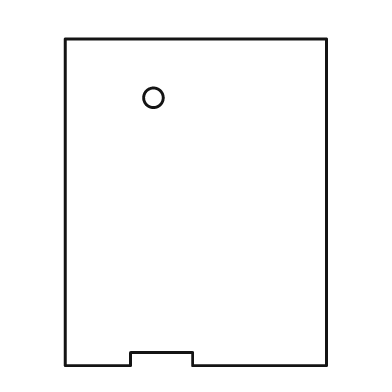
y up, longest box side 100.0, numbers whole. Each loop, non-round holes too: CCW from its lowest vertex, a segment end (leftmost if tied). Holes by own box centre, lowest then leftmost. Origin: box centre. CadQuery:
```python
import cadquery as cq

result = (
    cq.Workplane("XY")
    .moveTo(-40.0, -50.0)
    .lineTo(-20.0, -50.0)
    .lineTo(-20.0, -46.0)
    .lineTo(-1.0, -46.0)
    .lineTo(-1.0, -50.0)
    .lineTo(40.0, -50.0)
    .lineTo(40.0, 50.0)
    .lineTo(-40.0, 50.0)
    .close()
    .moveTo(-13.0, 32.0)
    .circle(3.0)
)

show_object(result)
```